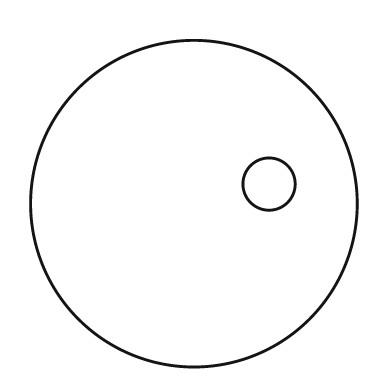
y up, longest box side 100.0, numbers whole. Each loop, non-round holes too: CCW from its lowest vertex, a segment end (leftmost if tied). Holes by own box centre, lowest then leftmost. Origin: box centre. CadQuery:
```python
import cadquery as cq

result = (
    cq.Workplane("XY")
    .moveTo(0.0, 0.0)
    .circle(50.0)
    .moveTo(23.0, 6.0)
    .circle(8.0)
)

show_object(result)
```